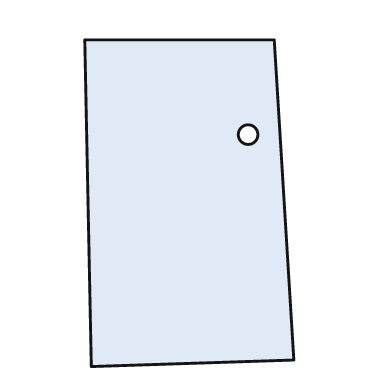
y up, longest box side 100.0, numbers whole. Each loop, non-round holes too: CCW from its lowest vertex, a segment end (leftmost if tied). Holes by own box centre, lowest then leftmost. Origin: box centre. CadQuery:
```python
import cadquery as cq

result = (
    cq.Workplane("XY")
    .moveTo(-30.0, -50.0)
    .lineTo(32.0, -48.0)
    .lineTo(26.0, 50.0)
    .lineTo(-32.0, 50.0)
    .close()
    .moveTo(18.0, 21.0)
    .circle(3.0)
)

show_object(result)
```